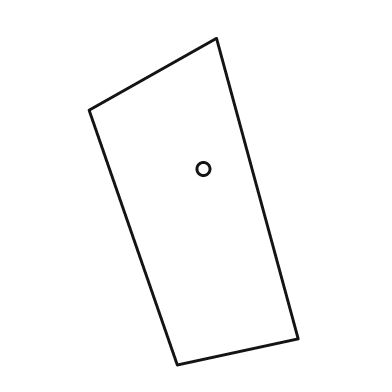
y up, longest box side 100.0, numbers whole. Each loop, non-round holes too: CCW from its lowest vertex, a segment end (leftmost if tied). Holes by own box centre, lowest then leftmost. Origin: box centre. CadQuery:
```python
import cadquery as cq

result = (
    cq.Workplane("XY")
    .moveTo(-5.0, -50.0)
    .lineTo(32.0, -42.0)
    .lineTo(7.0, 50.0)
    .lineTo(-32.0, 28.0)
    .close()
    .moveTo(3.0, 10.0)
    .circle(2.0)
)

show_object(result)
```